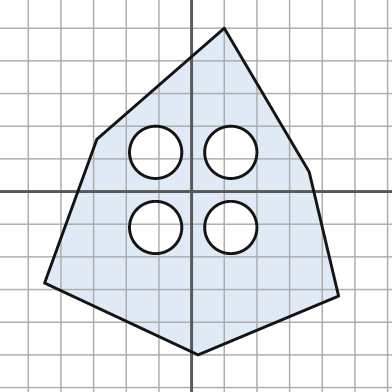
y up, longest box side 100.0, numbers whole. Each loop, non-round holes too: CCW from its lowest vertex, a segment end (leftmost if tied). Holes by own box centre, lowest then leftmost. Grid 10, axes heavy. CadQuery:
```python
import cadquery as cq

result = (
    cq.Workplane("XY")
    .moveTo(2.0, -50.0)
    .lineTo(45.0, -32.0)
    .lineTo(36.0, 6.0)
    .lineTo(10.0, 50.0)
    .lineTo(-29.0, 16.0)
    .lineTo(-45.0, -28.0)
    .close()
    .moveTo(-11.0, -11.0)
    .circle(8.0)
    .moveTo(12.0, -11.0)
    .circle(8.0)
    .moveTo(-11.0, 12.0)
    .circle(8.0)
    .moveTo(12.0, 12.0)
    .circle(8.0)
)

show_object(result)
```